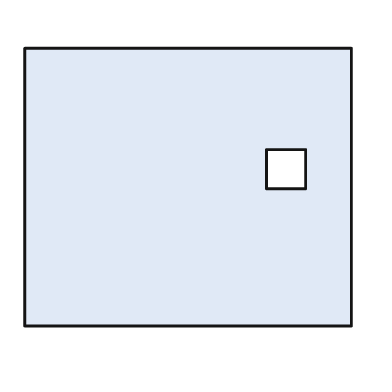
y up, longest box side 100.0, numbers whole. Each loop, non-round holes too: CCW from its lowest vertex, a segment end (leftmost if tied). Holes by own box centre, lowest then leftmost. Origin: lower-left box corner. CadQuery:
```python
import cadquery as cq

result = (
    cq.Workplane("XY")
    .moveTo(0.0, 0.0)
    .lineTo(100.0, 0.0)
    .lineTo(100.0, 85.0)
    .lineTo(0.0, 85.0)
    .close()
    .moveTo(74.0, 42.0)
    .lineTo(86.0, 42.0)
    .lineTo(86.0, 54.0)
    .lineTo(74.0, 54.0)
    .close()
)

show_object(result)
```